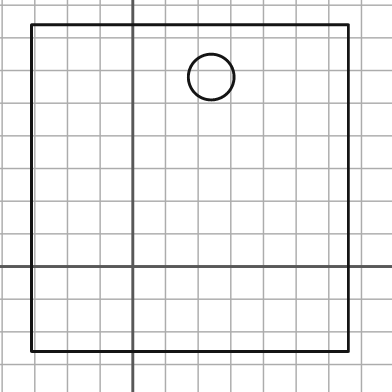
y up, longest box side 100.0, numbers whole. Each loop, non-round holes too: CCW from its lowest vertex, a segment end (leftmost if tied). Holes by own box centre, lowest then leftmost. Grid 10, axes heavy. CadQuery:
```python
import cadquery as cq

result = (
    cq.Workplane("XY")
    .moveTo(-31.0, -26.0)
    .lineTo(66.0, -26.0)
    .lineTo(66.0, 74.0)
    .lineTo(-31.0, 74.0)
    .close()
    .moveTo(24.0, 58.0)
    .circle(7.0)
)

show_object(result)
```